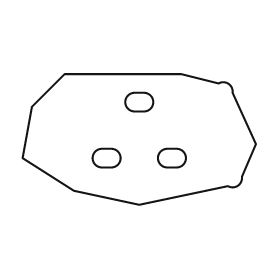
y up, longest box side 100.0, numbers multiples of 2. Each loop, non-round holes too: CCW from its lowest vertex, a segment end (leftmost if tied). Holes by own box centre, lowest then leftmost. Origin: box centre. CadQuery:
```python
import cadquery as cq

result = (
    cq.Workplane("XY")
    .moveTo(0.0, -28.0)
    .lineTo(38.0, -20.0)
    .threePointArc((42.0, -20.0), (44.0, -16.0))
    .lineTo(50.0, -2.0)
    .lineTo(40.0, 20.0)
    .threePointArc((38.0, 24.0), (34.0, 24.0))
    .lineTo(18.0, 28.0)
    .lineTo(-32.0, 28.0)
    .lineTo(-46.0, 14.0)
    .lineTo(-50.0, -8.0)
    .lineTo(-28.0, -22.0)
    .close()
    .moveTo(-16.0, -12.0)
    .lineTo(-12.0, -12.0)
    .threePointArc((-8.0, -8.0), (-12.0, -4.0))
    .lineTo(-16.0, -4.0)
    .threePointArc((-20.0, -8.0), (-16.0, -12.0))
    .close()
    .moveTo(12.0, -12.0)
    .lineTo(16.0, -12.0)
    .threePointArc((20.0, -8.0), (16.0, -4.0))
    .lineTo(12.0, -4.0)
    .threePointArc((8.0, -8.0), (12.0, -12.0))
    .close()
    .moveTo(-2.0, 12.0)
    .lineTo(2.0, 12.0)
    .threePointArc((6.0, 16.0), (2.0, 20.0))
    .lineTo(-2.0, 20.0)
    .threePointArc((-6.0, 16.0), (-2.0, 12.0))
    .close()
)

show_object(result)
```